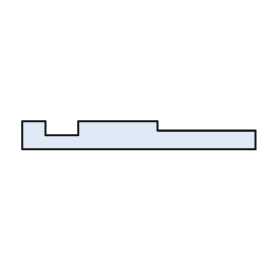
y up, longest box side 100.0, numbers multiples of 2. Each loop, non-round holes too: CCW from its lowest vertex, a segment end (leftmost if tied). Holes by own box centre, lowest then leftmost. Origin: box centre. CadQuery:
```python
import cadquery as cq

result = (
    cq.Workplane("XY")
    .moveTo(-50.0, -6.0)
    .lineTo(50.0, -6.0)
    .lineTo(50.0, 2.0)
    .lineTo(8.0, 2.0)
    .lineTo(8.0, 6.0)
    .lineTo(-26.0, 6.0)
    .lineTo(-26.0, 0.0)
    .lineTo(-40.0, 0.0)
    .lineTo(-40.0, 6.0)
    .lineTo(-50.0, 6.0)
    .close()
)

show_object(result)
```